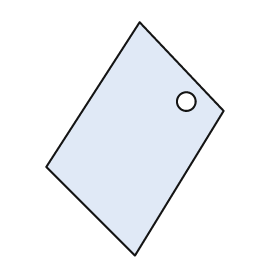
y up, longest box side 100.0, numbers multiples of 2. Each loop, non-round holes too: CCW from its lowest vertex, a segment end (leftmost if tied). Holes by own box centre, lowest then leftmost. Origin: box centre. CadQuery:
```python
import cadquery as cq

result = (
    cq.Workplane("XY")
    .moveTo(0.0, -50.0)
    .lineTo(38.0, 12.0)
    .lineTo(2.0, 50.0)
    .lineTo(-38.0, -12.0)
    .close()
    .moveTo(22.0, 16.0)
    .circle(4.0)
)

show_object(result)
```